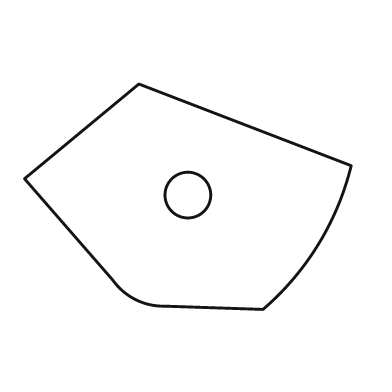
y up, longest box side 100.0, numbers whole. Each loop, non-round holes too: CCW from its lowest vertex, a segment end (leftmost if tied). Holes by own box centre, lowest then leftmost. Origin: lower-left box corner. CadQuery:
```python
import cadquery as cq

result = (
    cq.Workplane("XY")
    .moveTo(73.0, 0.0)
    .threePointArc((90.0, 20.0), (100.0, 44.0))
    .lineTo(35.0, 69.0)
    .lineTo(0.0, 40.0)
    .lineTo(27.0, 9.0)
    .threePointArc((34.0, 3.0), (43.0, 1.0))
    .close()
    .moveTo(50.0, 35.0)
    .circle(7.0)
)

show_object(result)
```